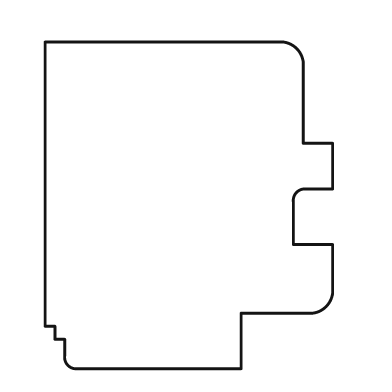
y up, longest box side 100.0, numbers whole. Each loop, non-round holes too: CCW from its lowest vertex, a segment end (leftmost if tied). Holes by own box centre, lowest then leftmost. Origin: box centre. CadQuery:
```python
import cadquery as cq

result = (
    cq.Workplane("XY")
    .moveTo(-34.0, -50.0)
    .lineTo(16.0, -50.0)
    .lineTo(16.0, -33.0)
    .lineTo(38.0, -33.0)
    .threePointArc((42.0, -31.0), (44.0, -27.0))
    .lineTo(44.0, -12.0)
    .lineTo(32.0, -12.0)
    .lineTo(32.0, 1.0)
    .threePointArc((33.0, 4.0), (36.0, 5.0))
    .lineTo(44.0, 5.0)
    .lineTo(44.0, 19.0)
    .lineTo(35.0, 19.0)
    .lineTo(35.0, 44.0)
    .threePointArc((33.0, 48.0), (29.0, 50.0))
    .lineTo(-44.0, 50.0)
    .lineTo(-44.0, -37.0)
    .lineTo(-41.0, -37.0)
    .lineTo(-41.0, -41.0)
    .lineTo(-38.0, -41.0)
    .lineTo(-38.0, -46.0)
    .threePointArc((-37.0, -49.0), (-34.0, -50.0))
    .close()
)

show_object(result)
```